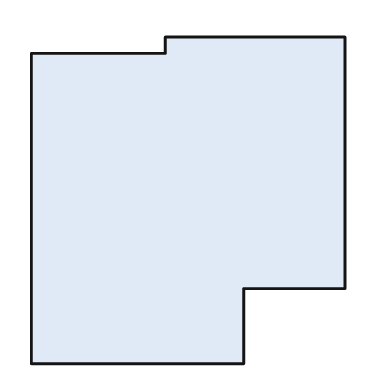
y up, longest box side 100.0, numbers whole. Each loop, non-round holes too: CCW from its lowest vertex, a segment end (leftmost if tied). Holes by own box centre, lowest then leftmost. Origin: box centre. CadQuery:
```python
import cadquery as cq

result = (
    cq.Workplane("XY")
    .moveTo(-48.0, -50.0)
    .lineTo(17.0, -50.0)
    .lineTo(17.0, -27.0)
    .lineTo(48.0, -27.0)
    .lineTo(48.0, 50.0)
    .lineTo(-7.0, 50.0)
    .lineTo(-7.0, 45.0)
    .lineTo(-48.0, 45.0)
    .close()
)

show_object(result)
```